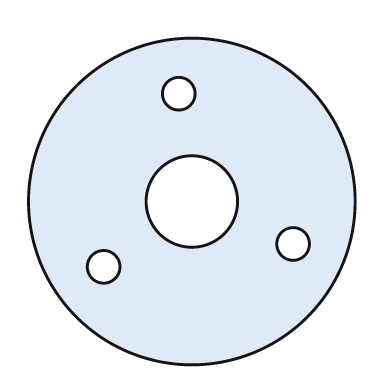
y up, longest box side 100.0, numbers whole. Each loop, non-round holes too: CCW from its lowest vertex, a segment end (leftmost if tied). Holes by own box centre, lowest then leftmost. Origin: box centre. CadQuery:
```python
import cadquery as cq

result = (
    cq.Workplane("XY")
    .moveTo(0.0, 0.0)
    .circle(50.0)
    .moveTo(-27.0, -20.0)
    .circle(5.0)
    .moveTo(31.0, -13.0)
    .circle(5.0)
    .moveTo(0.0, 0.0)
    .circle(14.0)
    .moveTo(-4.0, 33.0)
    .circle(5.0)
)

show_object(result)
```